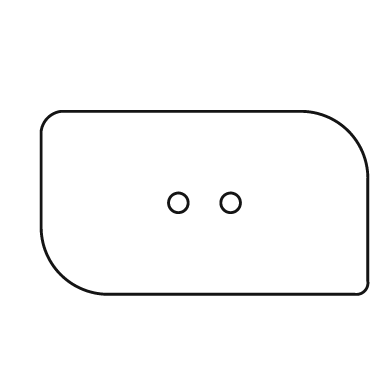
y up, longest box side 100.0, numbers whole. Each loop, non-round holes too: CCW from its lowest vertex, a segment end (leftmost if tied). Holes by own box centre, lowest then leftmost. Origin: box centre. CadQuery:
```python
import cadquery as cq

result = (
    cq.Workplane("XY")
    .moveTo(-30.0, -28.0)
    .lineTo(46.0, -28.0)
    .threePointArc((49.0, -27.0), (50.0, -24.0))
    .lineTo(50.0, 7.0)
    .threePointArc((44.0, 22.0), (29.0, 28.0))
    .lineTo(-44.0, 28.0)
    .threePointArc((-48.0, 26.0), (-50.0, 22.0))
    .lineTo(-50.0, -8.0)
    .threePointArc((-44.0, -22.0), (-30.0, -28.0))
    .close()
    .moveTo(-8.0, 0.0)
    .circle(3.0)
    .moveTo(8.0, 0.0)
    .circle(3.0)
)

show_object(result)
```